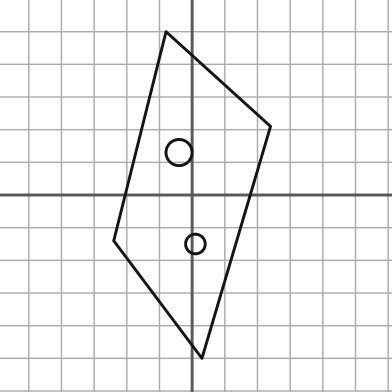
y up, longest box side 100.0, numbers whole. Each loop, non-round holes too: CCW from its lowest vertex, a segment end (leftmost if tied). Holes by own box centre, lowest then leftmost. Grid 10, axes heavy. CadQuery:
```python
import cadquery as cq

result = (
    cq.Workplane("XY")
    .moveTo(3.0, -50.0)
    .lineTo(24.0, 21.0)
    .lineTo(-8.0, 50.0)
    .lineTo(-24.0, -14.0)
    .close()
    .moveTo(1.0, -15.0)
    .circle(3.0)
    .moveTo(-4.0, 13.0)
    .circle(4.0)
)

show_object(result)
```